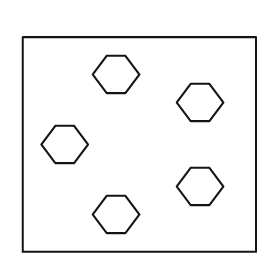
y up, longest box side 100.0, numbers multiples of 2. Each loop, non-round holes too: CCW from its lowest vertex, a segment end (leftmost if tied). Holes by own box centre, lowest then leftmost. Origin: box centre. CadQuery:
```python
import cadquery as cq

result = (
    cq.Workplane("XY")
    .moveTo(-50.0, -46.0)
    .lineTo(50.0, -46.0)
    .lineTo(50.0, 46.0)
    .lineTo(-50.0, 46.0)
    .close()
    .moveTo(-14.0, -38.0)
    .lineTo(-6.0, -38.0)
    .lineTo(0.0, -30.0)
    .lineTo(-6.0, -22.0)
    .lineTo(-14.0, -22.0)
    .lineTo(-20.0, -30.0)
    .close()
    .moveTo(22.0, -26.0)
    .lineTo(30.0, -26.0)
    .lineTo(36.0, -18.0)
    .lineTo(30.0, -10.0)
    .lineTo(22.0, -10.0)
    .lineTo(16.0, -18.0)
    .close()
    .moveTo(-36.0, -8.0)
    .lineTo(-28.0, -8.0)
    .lineTo(-22.0, 0.0)
    .lineTo(-28.0, 8.0)
    .lineTo(-36.0, 8.0)
    .lineTo(-42.0, 0.0)
    .close()
    .moveTo(22.0, 10.0)
    .lineTo(30.0, 10.0)
    .lineTo(36.0, 18.0)
    .lineTo(30.0, 26.0)
    .lineTo(22.0, 26.0)
    .lineTo(16.0, 18.0)
    .close()
    .moveTo(-14.0, 22.0)
    .lineTo(-6.0, 22.0)
    .lineTo(0.0, 30.0)
    .lineTo(-6.0, 38.0)
    .lineTo(-14.0, 38.0)
    .lineTo(-20.0, 30.0)
    .close()
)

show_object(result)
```